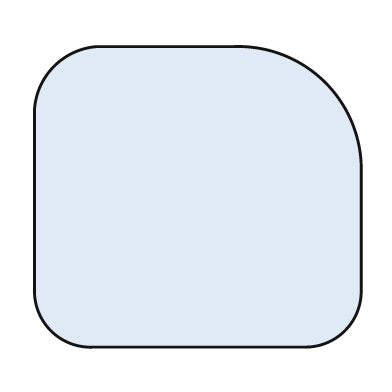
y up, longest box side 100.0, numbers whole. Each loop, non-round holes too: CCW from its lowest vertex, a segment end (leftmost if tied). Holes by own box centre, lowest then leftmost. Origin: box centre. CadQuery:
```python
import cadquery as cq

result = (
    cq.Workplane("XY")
    .moveTo(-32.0, -46.0)
    .lineTo(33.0, -46.0)
    .threePointArc((45.0, -41.0), (50.0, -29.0))
    .lineTo(50.0, 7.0)
    .threePointArc((39.0, 35.0), (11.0, 46.0))
    .lineTo(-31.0, 46.0)
    .threePointArc((-44.0, 40.0), (-50.0, 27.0))
    .lineTo(-50.0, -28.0)
    .threePointArc((-45.0, -41.0), (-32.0, -46.0))
    .close()
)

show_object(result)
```